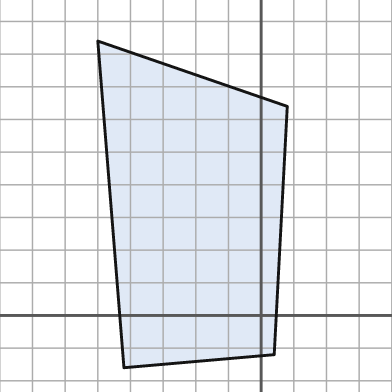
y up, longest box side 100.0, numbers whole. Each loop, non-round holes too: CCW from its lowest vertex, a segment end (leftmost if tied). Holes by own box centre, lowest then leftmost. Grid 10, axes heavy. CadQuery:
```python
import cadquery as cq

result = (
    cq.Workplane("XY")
    .moveTo(-42.0, -16.0)
    .lineTo(4.0, -12.0)
    .lineTo(8.0, 64.0)
    .lineTo(-50.0, 84.0)
    .close()
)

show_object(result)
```